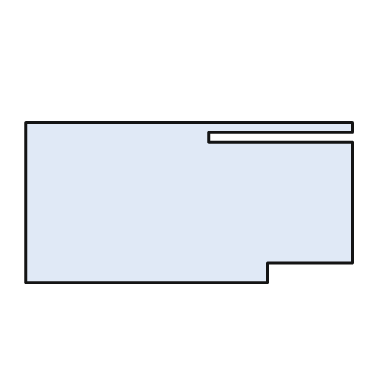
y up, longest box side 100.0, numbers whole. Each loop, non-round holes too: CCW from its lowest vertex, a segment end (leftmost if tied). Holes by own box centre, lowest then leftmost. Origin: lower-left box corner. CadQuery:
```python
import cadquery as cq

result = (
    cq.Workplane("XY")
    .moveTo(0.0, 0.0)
    .lineTo(74.0, 0.0)
    .lineTo(74.0, 6.0)
    .lineTo(100.0, 6.0)
    .lineTo(100.0, 43.0)
    .lineTo(56.0, 43.0)
    .lineTo(56.0, 46.0)
    .lineTo(100.0, 46.0)
    .lineTo(100.0, 49.0)
    .lineTo(0.0, 49.0)
    .close()
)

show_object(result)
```